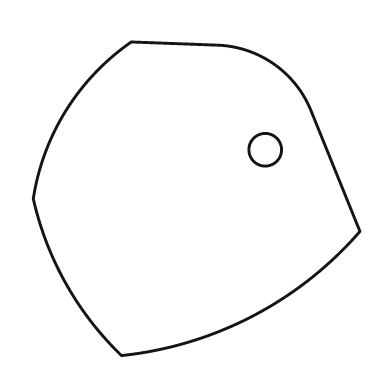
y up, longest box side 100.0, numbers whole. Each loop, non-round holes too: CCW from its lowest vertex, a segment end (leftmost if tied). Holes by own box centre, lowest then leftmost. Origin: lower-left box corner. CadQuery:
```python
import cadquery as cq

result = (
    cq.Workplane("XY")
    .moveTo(27.0, 0.0)
    .threePointArc((67.0, 12.0), (100.0, 38.0))
    .lineTo(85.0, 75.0)
    .threePointArc((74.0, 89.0), (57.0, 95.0))
    .lineTo(30.0, 96.0)
    .threePointArc((10.0, 75.0), (0.0, 48.0))
    .threePointArc((10.0, 22.0), (27.0, 0.0))
    .close()
    .moveTo(71.0, 63.0)
    .circle(5.0)
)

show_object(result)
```